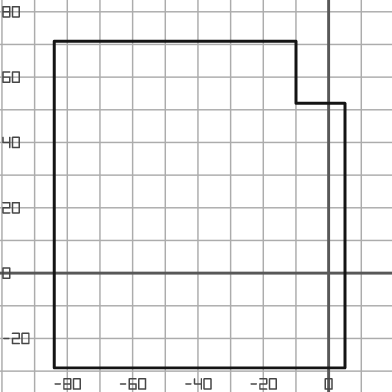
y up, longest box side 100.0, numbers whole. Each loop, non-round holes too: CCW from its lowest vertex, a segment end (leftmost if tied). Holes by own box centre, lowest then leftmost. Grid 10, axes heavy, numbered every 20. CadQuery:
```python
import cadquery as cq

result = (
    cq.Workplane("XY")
    .moveTo(-84.0, -29.0)
    .lineTo(5.0, -29.0)
    .lineTo(5.0, 52.0)
    .lineTo(-10.0, 52.0)
    .lineTo(-10.0, 71.0)
    .lineTo(-84.0, 71.0)
    .close()
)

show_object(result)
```